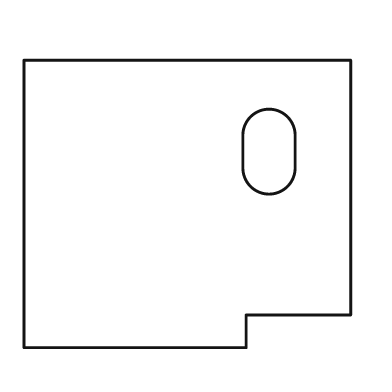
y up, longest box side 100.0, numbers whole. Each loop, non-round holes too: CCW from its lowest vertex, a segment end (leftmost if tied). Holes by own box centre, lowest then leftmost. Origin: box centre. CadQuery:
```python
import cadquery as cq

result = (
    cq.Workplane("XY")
    .moveTo(-50.0, -44.0)
    .lineTo(18.0, -44.0)
    .lineTo(18.0, -34.0)
    .lineTo(50.0, -34.0)
    .lineTo(50.0, 44.0)
    .lineTo(-50.0, 44.0)
    .close()
    .moveTo(17.0, 11.0)
    .threePointArc((25.0, 3.0), (33.0, 11.0))
    .lineTo(33.0, 21.0)
    .threePointArc((25.0, 29.0), (17.0, 21.0))
    .close()
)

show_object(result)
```